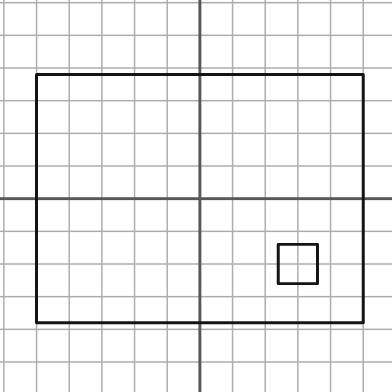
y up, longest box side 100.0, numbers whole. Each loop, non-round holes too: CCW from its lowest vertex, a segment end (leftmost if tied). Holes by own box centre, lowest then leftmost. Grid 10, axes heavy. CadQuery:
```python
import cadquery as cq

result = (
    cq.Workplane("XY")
    .moveTo(-50.0, -38.0)
    .lineTo(50.0, -38.0)
    .lineTo(50.0, 38.0)
    .lineTo(-50.0, 38.0)
    .close()
    .moveTo(24.0, -26.0)
    .lineTo(36.0, -26.0)
    .lineTo(36.0, -14.0)
    .lineTo(24.0, -14.0)
    .close()
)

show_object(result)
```